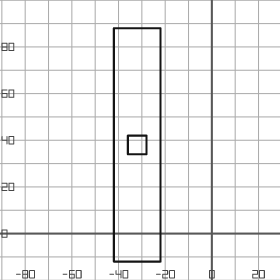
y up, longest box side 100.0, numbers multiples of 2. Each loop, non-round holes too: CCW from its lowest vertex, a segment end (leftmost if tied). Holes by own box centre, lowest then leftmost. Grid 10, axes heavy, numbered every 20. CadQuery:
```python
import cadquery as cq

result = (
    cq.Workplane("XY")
    .moveTo(-42.0, -12.0)
    .lineTo(-22.0, -12.0)
    .lineTo(-22.0, 88.0)
    .lineTo(-42.0, 88.0)
    .close()
    .moveTo(-36.0, 34.0)
    .lineTo(-28.0, 34.0)
    .lineTo(-28.0, 42.0)
    .lineTo(-36.0, 42.0)
    .close()
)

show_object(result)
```